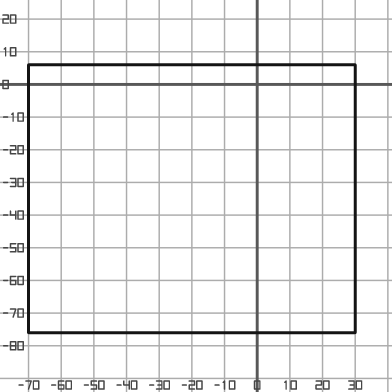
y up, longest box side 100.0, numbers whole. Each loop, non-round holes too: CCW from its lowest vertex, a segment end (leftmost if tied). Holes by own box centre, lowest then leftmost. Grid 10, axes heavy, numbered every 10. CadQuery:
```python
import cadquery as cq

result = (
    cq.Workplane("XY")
    .moveTo(-70.0, -76.0)
    .lineTo(30.0, -76.0)
    .lineTo(30.0, 6.0)
    .lineTo(-70.0, 6.0)
    .close()
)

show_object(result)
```